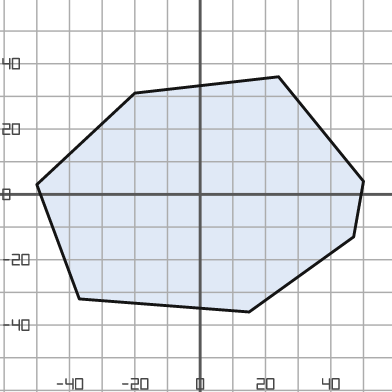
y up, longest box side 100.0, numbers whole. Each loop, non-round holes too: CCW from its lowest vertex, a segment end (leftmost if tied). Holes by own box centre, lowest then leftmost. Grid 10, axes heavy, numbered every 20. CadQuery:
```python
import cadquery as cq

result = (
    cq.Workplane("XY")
    .moveTo(15.0, -36.0)
    .lineTo(47.0, -13.0)
    .lineTo(50.0, 4.0)
    .lineTo(24.0, 36.0)
    .lineTo(-20.0, 31.0)
    .lineTo(-50.0, 3.0)
    .lineTo(-37.0, -32.0)
    .close()
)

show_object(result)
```